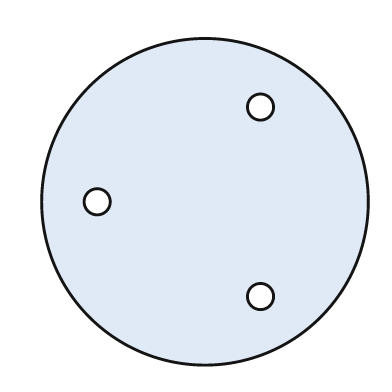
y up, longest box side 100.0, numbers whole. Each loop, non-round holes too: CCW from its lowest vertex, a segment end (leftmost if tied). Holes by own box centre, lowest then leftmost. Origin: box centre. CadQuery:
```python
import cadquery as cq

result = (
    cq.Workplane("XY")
    .moveTo(0.0, 0.0)
    .circle(50.0)
    .moveTo(17.0, -29.0)
    .circle(4.0)
    .moveTo(-33.0, 0.0)
    .circle(4.0)
    .moveTo(17.0, 29.0)
    .circle(4.0)
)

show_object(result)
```